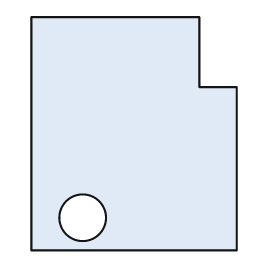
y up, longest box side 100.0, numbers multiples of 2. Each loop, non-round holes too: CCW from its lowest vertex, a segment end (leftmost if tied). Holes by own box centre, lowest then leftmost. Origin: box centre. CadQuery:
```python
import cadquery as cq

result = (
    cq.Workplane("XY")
    .moveTo(-44.0, -50.0)
    .lineTo(44.0, -50.0)
    .lineTo(44.0, 20.0)
    .lineTo(28.0, 20.0)
    .lineTo(28.0, 50.0)
    .lineTo(-44.0, 50.0)
    .close()
    .moveTo(-22.0, -36.0)
    .circle(10.0)
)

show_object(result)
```